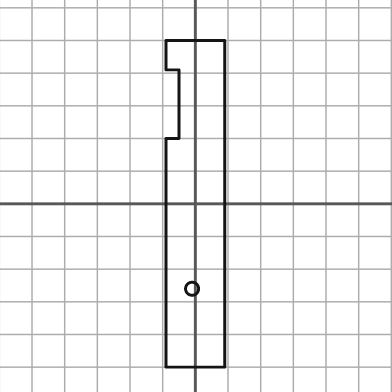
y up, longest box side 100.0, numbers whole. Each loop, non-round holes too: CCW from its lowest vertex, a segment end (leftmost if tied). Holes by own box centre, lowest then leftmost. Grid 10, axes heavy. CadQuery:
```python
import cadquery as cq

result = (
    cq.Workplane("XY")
    .moveTo(-9.0, -50.0)
    .lineTo(9.0, -50.0)
    .lineTo(9.0, 50.0)
    .lineTo(-9.0, 50.0)
    .lineTo(-9.0, 41.0)
    .lineTo(-5.0, 41.0)
    .lineTo(-5.0, 20.0)
    .lineTo(-9.0, 20.0)
    .close()
    .moveTo(-1.0, -26.0)
    .circle(2.0)
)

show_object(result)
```